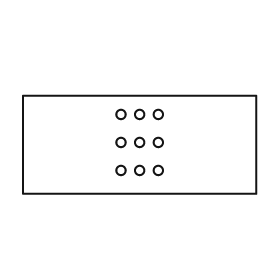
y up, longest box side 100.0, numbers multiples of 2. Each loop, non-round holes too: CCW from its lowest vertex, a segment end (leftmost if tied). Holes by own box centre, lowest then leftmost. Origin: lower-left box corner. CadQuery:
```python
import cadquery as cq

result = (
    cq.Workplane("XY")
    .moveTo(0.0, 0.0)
    .lineTo(100.0, 0.0)
    .lineTo(100.0, 42.0)
    .lineTo(0.0, 42.0)
    .close()
    .moveTo(42.0, 10.0)
    .circle(2.0)
    .moveTo(50.0, 10.0)
    .circle(2.0)
    .moveTo(58.0, 10.0)
    .circle(2.0)
    .moveTo(42.0, 22.0)
    .circle(2.0)
    .moveTo(50.0, 22.0)
    .circle(2.0)
    .moveTo(58.0, 22.0)
    .circle(2.0)
    .moveTo(42.0, 34.0)
    .circle(2.0)
    .moveTo(50.0, 34.0)
    .circle(2.0)
    .moveTo(58.0, 34.0)
    .circle(2.0)
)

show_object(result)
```